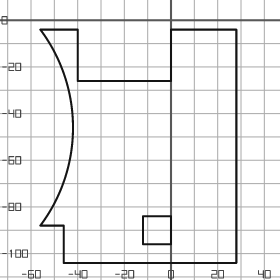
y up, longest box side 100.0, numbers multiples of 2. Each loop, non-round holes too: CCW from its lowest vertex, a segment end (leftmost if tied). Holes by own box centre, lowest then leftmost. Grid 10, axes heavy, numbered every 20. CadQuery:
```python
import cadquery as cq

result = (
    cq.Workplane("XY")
    .moveTo(-46.0, -104.0)
    .lineTo(28.0, -104.0)
    .lineTo(28.0, -4.0)
    .lineTo(0.0, -4.0)
    .lineTo(0.0, -26.0)
    .lineTo(-40.0, -26.0)
    .lineTo(-40.0, -4.0)
    .lineTo(-56.0, -4.0)
    .threePointArc((-42.0, -46.0), (-56.0, -88.0))
    .lineTo(-46.0, -88.0)
    .close()
    .moveTo(-12.0, -96.0)
    .lineTo(0.0, -96.0)
    .lineTo(0.0, -84.0)
    .lineTo(-12.0, -84.0)
    .close()
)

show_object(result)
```